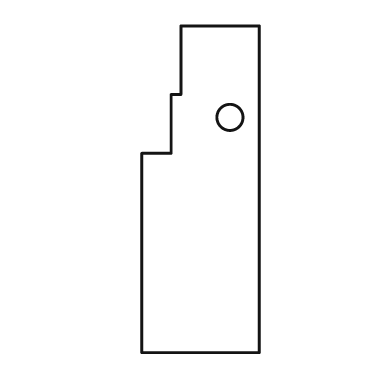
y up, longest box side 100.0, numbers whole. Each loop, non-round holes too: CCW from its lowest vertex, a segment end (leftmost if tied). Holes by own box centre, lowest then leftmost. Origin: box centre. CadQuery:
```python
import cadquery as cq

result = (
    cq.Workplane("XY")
    .moveTo(-18.0, -50.0)
    .lineTo(18.0, -50.0)
    .lineTo(18.0, 50.0)
    .lineTo(-6.0, 50.0)
    .lineTo(-6.0, 29.0)
    .lineTo(-9.0, 29.0)
    .lineTo(-9.0, 11.0)
    .lineTo(-18.0, 11.0)
    .close()
    .moveTo(9.0, 22.0)
    .circle(4.0)
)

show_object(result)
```